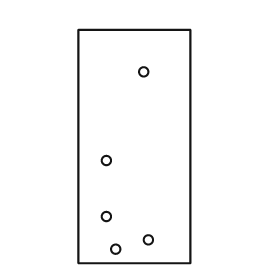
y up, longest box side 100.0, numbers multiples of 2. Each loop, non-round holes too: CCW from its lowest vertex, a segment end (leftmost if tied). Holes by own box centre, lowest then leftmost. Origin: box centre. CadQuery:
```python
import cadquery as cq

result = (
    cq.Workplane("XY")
    .moveTo(-24.0, -50.0)
    .lineTo(24.0, -50.0)
    .lineTo(24.0, 50.0)
    .lineTo(-24.0, 50.0)
    .close()
    .moveTo(-8.0, -44.0)
    .circle(2.0)
    .moveTo(6.0, -40.0)
    .circle(2.0)
    .moveTo(-12.0, -30.0)
    .circle(2.0)
    .moveTo(-12.0, -6.0)
    .circle(2.0)
    .moveTo(4.0, 32.0)
    .circle(2.0)
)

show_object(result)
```